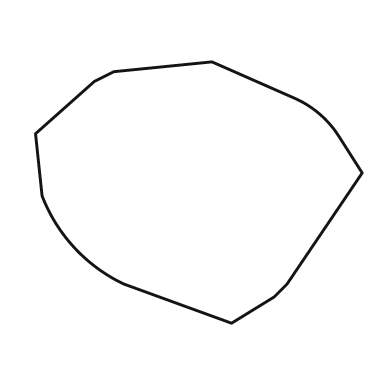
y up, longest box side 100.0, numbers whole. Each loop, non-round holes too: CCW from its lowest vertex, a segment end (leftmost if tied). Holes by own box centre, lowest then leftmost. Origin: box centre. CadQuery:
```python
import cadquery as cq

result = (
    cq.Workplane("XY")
    .moveTo(10.0, -40.0)
    .lineTo(23.0, -32.0)
    .lineTo(27.0, -28.0)
    .lineTo(50.0, 6.0)
    .lineTo(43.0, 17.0)
    .threePointArc((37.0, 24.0), (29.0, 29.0))
    .lineTo(4.0, 40.0)
    .lineTo(-26.0, 37.0)
    .lineTo(-32.0, 34.0)
    .lineTo(-50.0, 18.0)
    .lineTo(-48.0, -1.0)
    .threePointArc((-38.0, -17.0), (-23.0, -28.0))
    .close()
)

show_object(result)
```